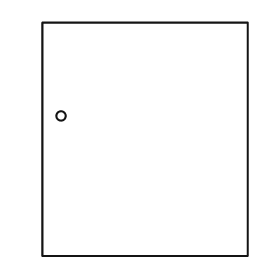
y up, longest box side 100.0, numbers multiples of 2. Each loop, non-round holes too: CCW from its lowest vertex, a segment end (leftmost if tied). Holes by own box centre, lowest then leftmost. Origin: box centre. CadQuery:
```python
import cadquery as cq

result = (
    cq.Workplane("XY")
    .moveTo(-44.0, -50.0)
    .lineTo(44.0, -50.0)
    .lineTo(44.0, 50.0)
    .lineTo(-44.0, 50.0)
    .close()
    .moveTo(-36.0, 10.0)
    .circle(2.0)
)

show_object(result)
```